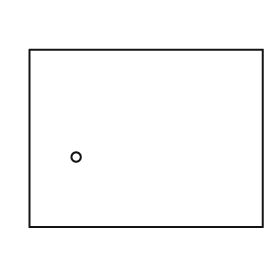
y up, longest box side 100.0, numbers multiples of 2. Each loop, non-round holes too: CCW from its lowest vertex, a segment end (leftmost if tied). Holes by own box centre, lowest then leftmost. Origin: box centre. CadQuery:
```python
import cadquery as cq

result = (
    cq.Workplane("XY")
    .moveTo(-50.0, -38.0)
    .lineTo(50.0, -38.0)
    .lineTo(50.0, 38.0)
    .lineTo(-50.0, 38.0)
    .close()
    .moveTo(-30.0, -8.0)
    .circle(2.0)
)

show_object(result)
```